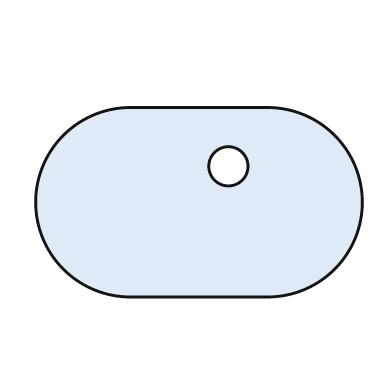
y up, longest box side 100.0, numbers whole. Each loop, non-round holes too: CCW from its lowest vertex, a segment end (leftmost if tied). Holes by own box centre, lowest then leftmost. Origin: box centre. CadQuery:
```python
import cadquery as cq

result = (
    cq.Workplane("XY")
    .moveTo(-21.0, -29.0)
    .lineTo(21.0, -29.0)
    .threePointArc((50.0, 0.0), (21.0, 29.0))
    .lineTo(-21.0, 29.0)
    .threePointArc((-50.0, 0.0), (-21.0, -29.0))
    .close()
    .moveTo(9.0, 11.0)
    .circle(6.0)
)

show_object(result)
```